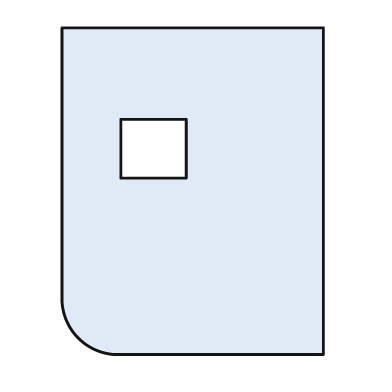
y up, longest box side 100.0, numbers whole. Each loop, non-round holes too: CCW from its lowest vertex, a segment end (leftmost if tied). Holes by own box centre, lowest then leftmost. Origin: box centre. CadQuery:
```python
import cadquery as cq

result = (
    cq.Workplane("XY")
    .moveTo(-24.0, -50.0)
    .lineTo(40.0, -50.0)
    .lineTo(40.0, 50.0)
    .lineTo(-40.0, 50.0)
    .lineTo(-40.0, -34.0)
    .threePointArc((-35.0, -45.0), (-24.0, -50.0))
    .close()
    .moveTo(-22.0, 4.0)
    .lineTo(-2.0, 4.0)
    .lineTo(-2.0, 22.0)
    .lineTo(-22.0, 22.0)
    .close()
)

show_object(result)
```